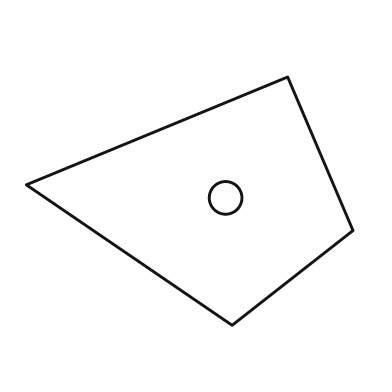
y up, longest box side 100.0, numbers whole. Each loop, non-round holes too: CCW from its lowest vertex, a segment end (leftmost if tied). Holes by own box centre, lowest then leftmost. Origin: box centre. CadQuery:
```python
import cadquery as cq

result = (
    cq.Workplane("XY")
    .moveTo(13.0, -38.0)
    .lineTo(50.0, -9.0)
    .lineTo(30.0, 38.0)
    .lineTo(-50.0, 5.0)
    .close()
    .moveTo(11.0, 1.0)
    .circle(5.0)
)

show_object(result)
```